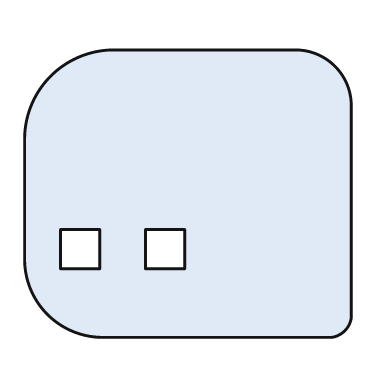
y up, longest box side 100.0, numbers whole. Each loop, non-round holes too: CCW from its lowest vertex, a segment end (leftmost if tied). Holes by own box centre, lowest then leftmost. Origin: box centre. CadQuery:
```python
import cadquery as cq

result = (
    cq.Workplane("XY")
    .moveTo(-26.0, -44.0)
    .lineTo(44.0, -44.0)
    .threePointArc((48.0, -42.0), (50.0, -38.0))
    .lineTo(50.0, 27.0)
    .threePointArc((45.0, 39.0), (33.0, 44.0))
    .lineTo(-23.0, 44.0)
    .threePointArc((-42.0, 36.0), (-50.0, 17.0))
    .lineTo(-50.0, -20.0)
    .threePointArc((-43.0, -37.0), (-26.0, -44.0))
    .close()
    .moveTo(-39.0, -23.0)
    .lineTo(-27.0, -23.0)
    .lineTo(-27.0, -11.0)
    .lineTo(-39.0, -11.0)
    .close()
    .moveTo(-13.0, -23.0)
    .lineTo(-1.0, -23.0)
    .lineTo(-1.0, -11.0)
    .lineTo(-13.0, -11.0)
    .close()
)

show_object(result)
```